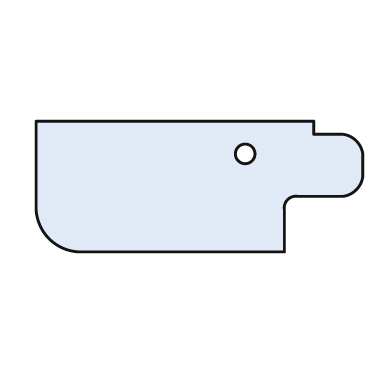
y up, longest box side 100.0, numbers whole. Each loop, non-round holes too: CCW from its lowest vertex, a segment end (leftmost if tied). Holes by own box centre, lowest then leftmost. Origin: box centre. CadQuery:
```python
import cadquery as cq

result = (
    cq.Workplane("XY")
    .moveTo(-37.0, -20.0)
    .lineTo(26.0, -20.0)
    .lineTo(26.0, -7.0)
    .threePointArc((27.0, -4.0), (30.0, -3.0))
    .lineTo(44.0, -3.0)
    .threePointArc((48.0, -1.0), (50.0, 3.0))
    .lineTo(50.0, 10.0)
    .threePointArc((48.0, 14.0), (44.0, 16.0))
    .lineTo(35.0, 16.0)
    .lineTo(35.0, 20.0)
    .lineTo(-50.0, 20.0)
    .lineTo(-50.0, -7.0)
    .threePointArc((-46.0, -16.0), (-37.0, -20.0))
    .close()
    .moveTo(14.0, 10.0)
    .circle(3.0)
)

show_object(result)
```